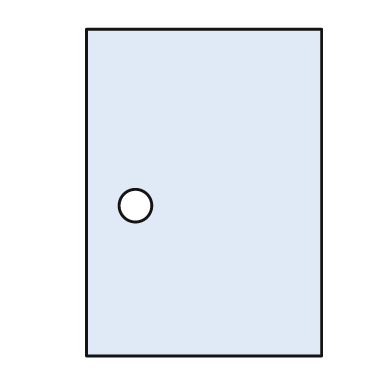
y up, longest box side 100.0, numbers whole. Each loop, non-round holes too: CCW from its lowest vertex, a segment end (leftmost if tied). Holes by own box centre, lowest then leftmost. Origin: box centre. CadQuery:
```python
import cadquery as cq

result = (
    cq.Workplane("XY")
    .moveTo(-36.0, -50.0)
    .lineTo(36.0, -50.0)
    .lineTo(36.0, 50.0)
    .lineTo(-36.0, 50.0)
    .close()
    .moveTo(-21.0, -4.0)
    .circle(5.0)
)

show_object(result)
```